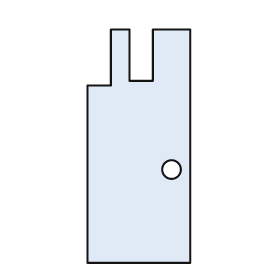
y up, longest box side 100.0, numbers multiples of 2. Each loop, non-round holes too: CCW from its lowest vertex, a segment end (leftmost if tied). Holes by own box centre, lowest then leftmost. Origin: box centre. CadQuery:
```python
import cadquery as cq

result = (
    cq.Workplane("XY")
    .moveTo(-22.0, -50.0)
    .lineTo(22.0, -50.0)
    .lineTo(22.0, 50.0)
    .lineTo(6.0, 50.0)
    .lineTo(6.0, 28.0)
    .lineTo(-4.0, 28.0)
    .lineTo(-4.0, 50.0)
    .lineTo(-12.0, 50.0)
    .lineTo(-12.0, 26.0)
    .lineTo(-22.0, 26.0)
    .close()
    .moveTo(14.0, -10.0)
    .circle(4.0)
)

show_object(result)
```